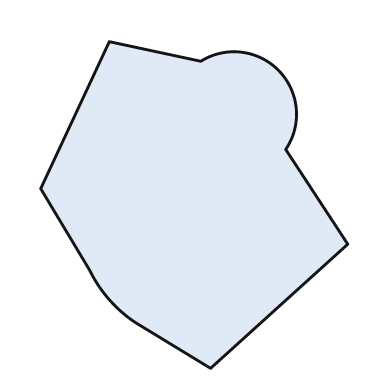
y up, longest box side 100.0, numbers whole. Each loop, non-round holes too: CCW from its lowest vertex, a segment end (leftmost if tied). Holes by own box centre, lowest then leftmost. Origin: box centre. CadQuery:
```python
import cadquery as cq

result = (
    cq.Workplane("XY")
    .moveTo(5.0, -50.0)
    .lineTo(47.0, -12.0)
    .lineTo(28.0, 17.0)
    .threePointArc((26.0, 41.0), (2.0, 44.0))
    .lineTo(-26.0, 50.0)
    .lineTo(-47.0, 5.0)
    .lineTo(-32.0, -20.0)
    .threePointArc((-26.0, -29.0), (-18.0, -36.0))
    .close()
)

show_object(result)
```